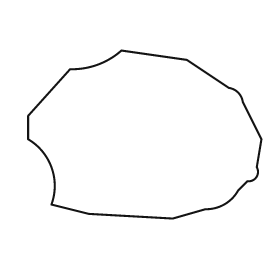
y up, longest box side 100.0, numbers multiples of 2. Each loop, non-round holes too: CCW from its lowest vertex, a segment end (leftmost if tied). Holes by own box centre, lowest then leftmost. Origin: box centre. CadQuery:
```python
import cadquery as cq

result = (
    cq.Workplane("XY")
    .moveTo(12.0, -36.0)
    .lineTo(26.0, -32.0)
    .threePointArc((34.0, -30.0), (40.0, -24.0))
    .lineTo(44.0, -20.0)
    .threePointArc((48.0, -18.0), (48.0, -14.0))
    .lineTo(50.0, -2.0)
    .lineTo(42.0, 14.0)
    .threePointArc((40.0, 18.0), (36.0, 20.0))
    .lineTo(18.0, 32.0)
    .lineTo(-10.0, 36.0)
    .threePointArc((-20.0, 30.0), (-32.0, 28.0))
    .lineTo(-50.0, 8.0)
    .lineTo(-50.0, -2.0)
    .threePointArc((-40.0, -14.0), (-40.0, -30.0))
    .lineTo(-24.0, -34.0)
    .close()
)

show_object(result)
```